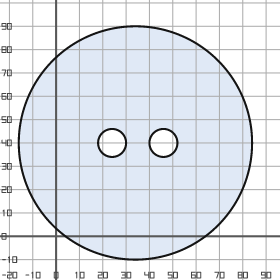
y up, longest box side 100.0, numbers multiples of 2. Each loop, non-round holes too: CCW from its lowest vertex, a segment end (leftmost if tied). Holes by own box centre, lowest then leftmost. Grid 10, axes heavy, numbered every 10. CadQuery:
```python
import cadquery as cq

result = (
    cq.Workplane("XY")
    .moveTo(34.0, 40.0)
    .circle(50.0)
    .moveTo(24.0, 40.0)
    .circle(6.0)
    .moveTo(46.0, 40.0)
    .circle(6.0)
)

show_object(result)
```